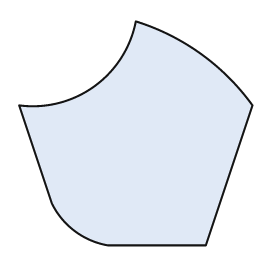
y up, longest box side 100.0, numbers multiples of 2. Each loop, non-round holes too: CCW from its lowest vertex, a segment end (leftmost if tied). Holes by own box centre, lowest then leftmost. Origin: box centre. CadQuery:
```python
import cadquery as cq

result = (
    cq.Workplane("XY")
    .moveTo(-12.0, -48.0)
    .lineTo(30.0, -48.0)
    .lineTo(50.0, 12.0)
    .threePointArc((28.0, 34.0), (0.0, 48.0))
    .threePointArc((-18.0, 20.0), (-50.0, 12.0))
    .lineTo(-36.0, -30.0)
    .threePointArc((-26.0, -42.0), (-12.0, -48.0))
    .close()
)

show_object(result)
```